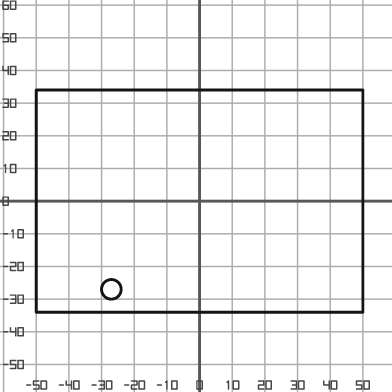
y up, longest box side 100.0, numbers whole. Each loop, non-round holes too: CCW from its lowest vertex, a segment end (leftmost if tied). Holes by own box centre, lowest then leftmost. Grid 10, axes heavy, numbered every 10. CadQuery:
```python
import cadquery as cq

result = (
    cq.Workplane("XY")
    .moveTo(-50.0, -34.0)
    .lineTo(50.0, -34.0)
    .lineTo(50.0, 34.0)
    .lineTo(-50.0, 34.0)
    .close()
    .moveTo(-27.0, -27.0)
    .circle(3.0)
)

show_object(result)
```